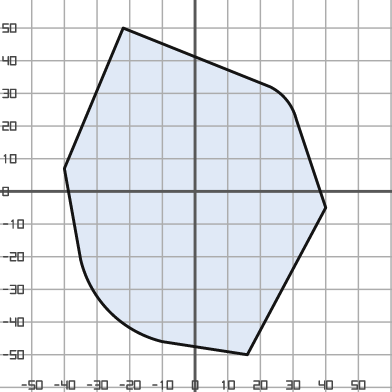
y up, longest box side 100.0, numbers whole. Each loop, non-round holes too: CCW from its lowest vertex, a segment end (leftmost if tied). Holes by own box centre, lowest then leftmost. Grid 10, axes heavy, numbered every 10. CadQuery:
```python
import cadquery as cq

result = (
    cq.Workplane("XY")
    .moveTo(16.0, -50.0)
    .lineTo(40.0, -5.0)
    .lineTo(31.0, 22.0)
    .threePointArc((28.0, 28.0), (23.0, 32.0))
    .lineTo(-22.0, 50.0)
    .lineTo(-40.0, 7.0)
    .lineTo(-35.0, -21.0)
    .threePointArc((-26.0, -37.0), (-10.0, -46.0))
    .close()
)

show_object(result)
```